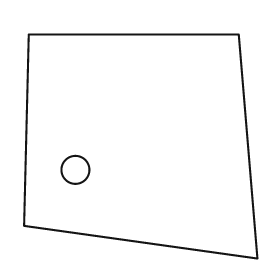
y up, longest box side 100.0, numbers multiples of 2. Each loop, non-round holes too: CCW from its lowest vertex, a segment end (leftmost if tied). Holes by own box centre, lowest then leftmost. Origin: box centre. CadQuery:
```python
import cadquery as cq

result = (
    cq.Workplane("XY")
    .moveTo(50.0, -48.0)
    .lineTo(42.0, 48.0)
    .lineTo(-48.0, 48.0)
    .lineTo(-50.0, -34.0)
    .close()
    .moveTo(-28.0, -10.0)
    .circle(6.0)
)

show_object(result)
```